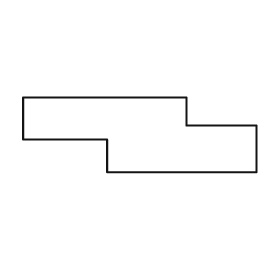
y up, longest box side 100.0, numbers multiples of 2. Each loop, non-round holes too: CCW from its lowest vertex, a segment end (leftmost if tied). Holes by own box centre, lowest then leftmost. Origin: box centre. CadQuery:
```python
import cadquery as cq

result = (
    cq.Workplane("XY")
    .moveTo(-14.0, -16.0)
    .lineTo(50.0, -16.0)
    .lineTo(50.0, 4.0)
    .lineTo(20.0, 4.0)
    .lineTo(20.0, 16.0)
    .lineTo(-50.0, 16.0)
    .lineTo(-50.0, -2.0)
    .lineTo(-14.0, -2.0)
    .close()
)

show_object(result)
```